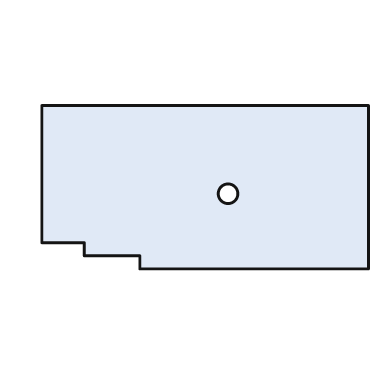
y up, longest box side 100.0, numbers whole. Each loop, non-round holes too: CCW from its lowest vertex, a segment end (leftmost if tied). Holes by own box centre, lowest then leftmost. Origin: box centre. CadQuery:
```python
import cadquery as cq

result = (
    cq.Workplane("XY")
    .moveTo(-20.0, -25.0)
    .lineTo(50.0, -25.0)
    .lineTo(50.0, 25.0)
    .lineTo(-50.0, 25.0)
    .lineTo(-50.0, -17.0)
    .lineTo(-37.0, -17.0)
    .lineTo(-37.0, -21.0)
    .lineTo(-20.0, -21.0)
    .close()
    .moveTo(7.0, -2.0)
    .circle(3.0)
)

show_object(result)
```